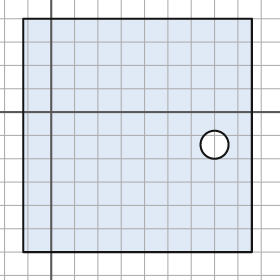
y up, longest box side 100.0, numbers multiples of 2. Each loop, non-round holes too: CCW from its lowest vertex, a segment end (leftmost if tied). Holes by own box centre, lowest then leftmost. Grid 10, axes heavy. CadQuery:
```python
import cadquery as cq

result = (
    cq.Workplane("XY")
    .moveTo(-12.0, -60.0)
    .lineTo(86.0, -60.0)
    .lineTo(86.0, 40.0)
    .lineTo(-12.0, 40.0)
    .close()
    .moveTo(70.0, -14.0)
    .circle(6.0)
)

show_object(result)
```